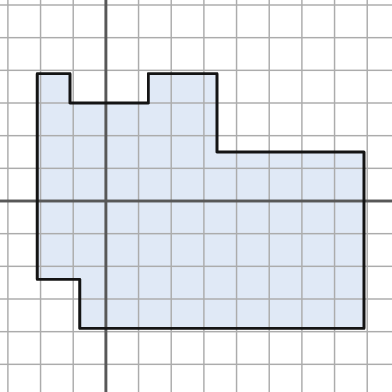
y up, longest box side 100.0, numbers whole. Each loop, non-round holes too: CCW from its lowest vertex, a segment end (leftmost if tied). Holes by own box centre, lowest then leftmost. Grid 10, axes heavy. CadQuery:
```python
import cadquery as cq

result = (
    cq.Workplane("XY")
    .moveTo(-8.0, -39.0)
    .lineTo(79.0, -39.0)
    .lineTo(79.0, 15.0)
    .lineTo(34.0, 15.0)
    .lineTo(34.0, 39.0)
    .lineTo(13.0, 39.0)
    .lineTo(13.0, 30.0)
    .lineTo(-11.0, 30.0)
    .lineTo(-11.0, 39.0)
    .lineTo(-21.0, 39.0)
    .lineTo(-21.0, -24.0)
    .lineTo(-8.0, -24.0)
    .close()
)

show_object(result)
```